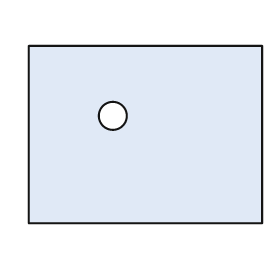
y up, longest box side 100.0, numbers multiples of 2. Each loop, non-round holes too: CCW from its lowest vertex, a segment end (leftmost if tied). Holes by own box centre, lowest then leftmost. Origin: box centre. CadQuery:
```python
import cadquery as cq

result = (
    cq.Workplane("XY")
    .moveTo(-50.0, -38.0)
    .lineTo(50.0, -38.0)
    .lineTo(50.0, 38.0)
    .lineTo(-50.0, 38.0)
    .close()
    .moveTo(-14.0, 8.0)
    .circle(6.0)
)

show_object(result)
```